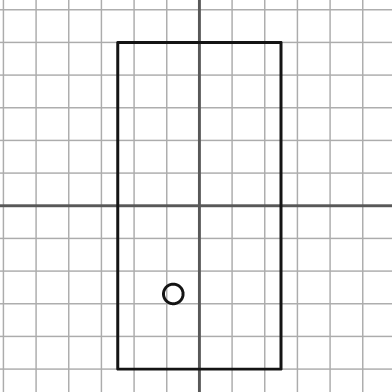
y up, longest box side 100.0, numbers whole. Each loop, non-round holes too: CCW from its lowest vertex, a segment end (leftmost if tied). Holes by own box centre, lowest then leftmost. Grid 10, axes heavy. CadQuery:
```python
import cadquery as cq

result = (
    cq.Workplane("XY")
    .moveTo(-25.0, -50.0)
    .lineTo(25.0, -50.0)
    .lineTo(25.0, 50.0)
    .lineTo(-25.0, 50.0)
    .close()
    .moveTo(-8.0, -27.0)
    .circle(3.0)
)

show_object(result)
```